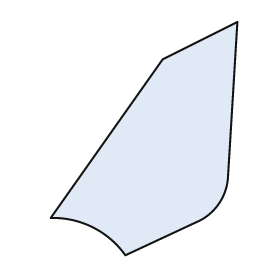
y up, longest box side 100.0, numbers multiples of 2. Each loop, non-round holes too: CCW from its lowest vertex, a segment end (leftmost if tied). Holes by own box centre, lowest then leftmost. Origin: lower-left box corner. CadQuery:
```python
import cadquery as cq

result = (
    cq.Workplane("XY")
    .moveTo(32.0, 0.0)
    .lineTo(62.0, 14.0)
    .threePointArc((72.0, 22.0), (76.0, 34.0))
    .lineTo(80.0, 100.0)
    .lineTo(48.0, 84.0)
    .lineTo(0.0, 16.0)
    .threePointArc((18.0, 12.0), (32.0, 0.0))
    .close()
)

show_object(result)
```